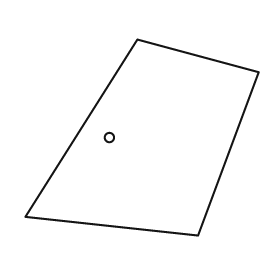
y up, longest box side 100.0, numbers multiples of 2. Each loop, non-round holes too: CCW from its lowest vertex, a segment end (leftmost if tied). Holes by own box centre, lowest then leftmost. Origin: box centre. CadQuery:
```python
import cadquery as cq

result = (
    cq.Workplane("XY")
    .moveTo(24.0, -42.0)
    .lineTo(50.0, 28.0)
    .lineTo(-2.0, 42.0)
    .lineTo(-50.0, -34.0)
    .close()
    .moveTo(-14.0, 0.0)
    .circle(2.0)
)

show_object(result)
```